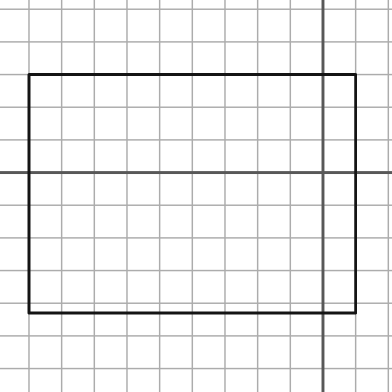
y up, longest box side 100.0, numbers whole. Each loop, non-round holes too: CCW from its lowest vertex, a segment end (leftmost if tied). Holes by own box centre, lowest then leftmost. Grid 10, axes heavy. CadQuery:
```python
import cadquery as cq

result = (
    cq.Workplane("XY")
    .moveTo(-90.0, -43.0)
    .lineTo(10.0, -43.0)
    .lineTo(10.0, 30.0)
    .lineTo(-90.0, 30.0)
    .close()
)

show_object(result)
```